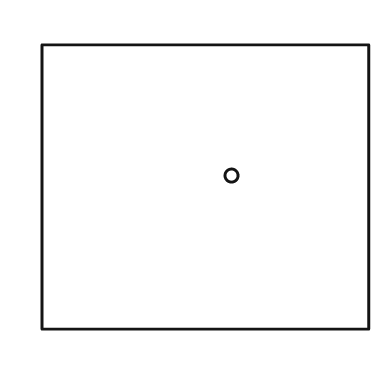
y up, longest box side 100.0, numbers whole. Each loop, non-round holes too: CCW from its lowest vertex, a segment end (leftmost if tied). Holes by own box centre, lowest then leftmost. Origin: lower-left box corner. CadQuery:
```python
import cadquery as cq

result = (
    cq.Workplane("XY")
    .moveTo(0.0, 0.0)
    .lineTo(100.0, 0.0)
    .lineTo(100.0, 87.0)
    .lineTo(0.0, 87.0)
    .close()
    .moveTo(58.0, 47.0)
    .circle(2.0)
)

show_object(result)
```